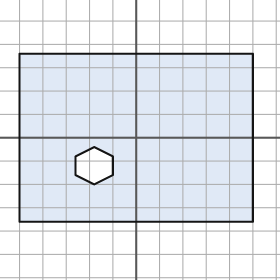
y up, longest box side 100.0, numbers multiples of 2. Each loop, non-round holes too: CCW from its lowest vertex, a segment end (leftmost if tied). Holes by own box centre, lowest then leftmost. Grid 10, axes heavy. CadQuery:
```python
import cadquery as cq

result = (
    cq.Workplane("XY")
    .moveTo(-50.0, -36.0)
    .lineTo(50.0, -36.0)
    .lineTo(50.0, 36.0)
    .lineTo(-50.0, 36.0)
    .close()
    .moveTo(-18.0, -20.0)
    .lineTo(-10.0, -16.0)
    .lineTo(-10.0, -8.0)
    .lineTo(-18.0, -4.0)
    .lineTo(-26.0, -8.0)
    .lineTo(-26.0, -16.0)
    .close()
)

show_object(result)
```